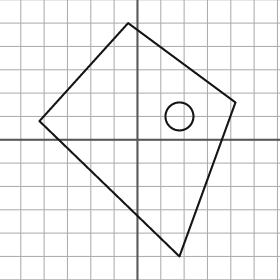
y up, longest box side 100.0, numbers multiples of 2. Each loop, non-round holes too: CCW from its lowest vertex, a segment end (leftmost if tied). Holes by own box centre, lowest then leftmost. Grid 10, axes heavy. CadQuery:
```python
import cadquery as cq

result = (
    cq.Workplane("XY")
    .moveTo(18.0, -50.0)
    .lineTo(42.0, 16.0)
    .lineTo(-4.0, 50.0)
    .lineTo(-42.0, 8.0)
    .close()
    .moveTo(18.0, 10.0)
    .circle(6.0)
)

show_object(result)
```